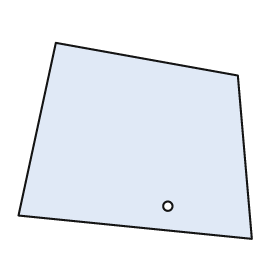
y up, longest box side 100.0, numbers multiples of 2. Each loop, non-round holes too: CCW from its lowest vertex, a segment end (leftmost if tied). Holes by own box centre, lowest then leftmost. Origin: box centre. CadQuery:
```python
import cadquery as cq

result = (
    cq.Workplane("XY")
    .moveTo(50.0, -42.0)
    .lineTo(44.0, 28.0)
    .lineTo(-34.0, 42.0)
    .lineTo(-50.0, -32.0)
    .close()
    .moveTo(14.0, -28.0)
    .circle(2.0)
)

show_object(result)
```